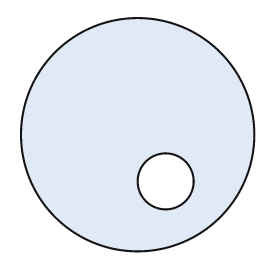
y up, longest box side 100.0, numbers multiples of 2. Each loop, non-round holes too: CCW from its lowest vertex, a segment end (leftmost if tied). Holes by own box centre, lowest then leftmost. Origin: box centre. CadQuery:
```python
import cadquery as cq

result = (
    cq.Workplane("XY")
    .moveTo(0.0, 0.0)
    .circle(50.0)
    .moveTo(12.0, -20.0)
    .circle(12.0)
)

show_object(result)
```